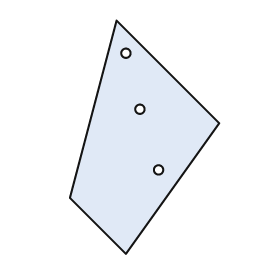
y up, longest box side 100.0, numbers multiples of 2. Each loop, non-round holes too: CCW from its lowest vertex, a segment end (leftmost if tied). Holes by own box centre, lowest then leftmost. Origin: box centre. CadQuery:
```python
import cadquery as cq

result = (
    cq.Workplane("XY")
    .moveTo(-8.0, -50.0)
    .lineTo(32.0, 6.0)
    .lineTo(-12.0, 50.0)
    .lineTo(-32.0, -26.0)
    .close()
    .moveTo(6.0, -14.0)
    .circle(2.0)
    .moveTo(-2.0, 12.0)
    .circle(2.0)
    .moveTo(-8.0, 36.0)
    .circle(2.0)
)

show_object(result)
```